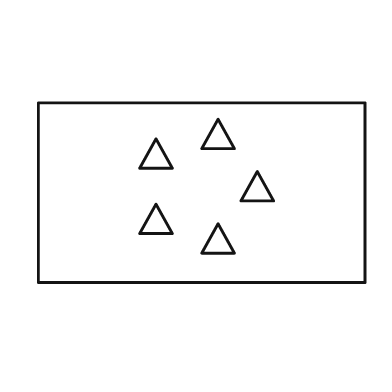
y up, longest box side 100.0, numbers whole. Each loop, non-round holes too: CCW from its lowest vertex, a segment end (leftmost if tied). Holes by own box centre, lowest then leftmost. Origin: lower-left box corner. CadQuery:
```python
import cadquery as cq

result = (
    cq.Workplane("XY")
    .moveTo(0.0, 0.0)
    .lineTo(100.0, 0.0)
    .lineTo(100.0, 55.0)
    .lineTo(0.0, 55.0)
    .close()
    .moveTo(50.0, 9.0)
    .lineTo(60.0, 9.0)
    .lineTo(55.0, 18.0)
    .close()
    .moveTo(31.0, 15.0)
    .lineTo(41.0, 15.0)
    .lineTo(36.0, 24.0)
    .close()
    .moveTo(62.0, 25.0)
    .lineTo(72.0, 25.0)
    .lineTo(67.0, 34.0)
    .close()
    .moveTo(31.0, 35.0)
    .lineTo(41.0, 35.0)
    .lineTo(36.0, 44.0)
    .close()
    .moveTo(50.0, 41.0)
    .lineTo(60.0, 41.0)
    .lineTo(55.0, 50.0)
    .close()
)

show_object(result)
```